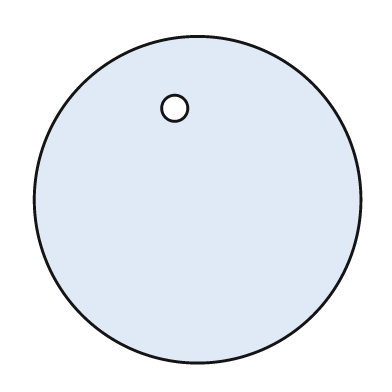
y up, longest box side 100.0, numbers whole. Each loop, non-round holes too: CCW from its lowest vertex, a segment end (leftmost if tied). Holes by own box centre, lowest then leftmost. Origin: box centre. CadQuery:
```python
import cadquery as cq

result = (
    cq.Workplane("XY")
    .moveTo(0.0, 0.0)
    .circle(50.0)
    .moveTo(-7.0, 28.0)
    .circle(4.0)
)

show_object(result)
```